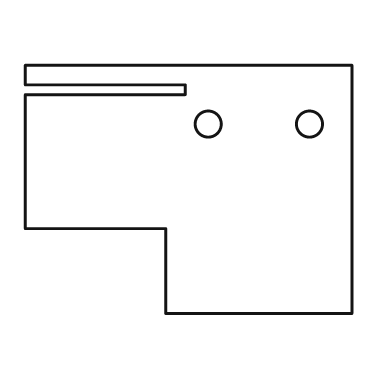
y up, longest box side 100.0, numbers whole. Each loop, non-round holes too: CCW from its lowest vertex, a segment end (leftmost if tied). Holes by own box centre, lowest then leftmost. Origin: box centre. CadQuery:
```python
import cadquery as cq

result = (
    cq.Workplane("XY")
    .moveTo(-7.0, -38.0)
    .lineTo(50.0, -38.0)
    .lineTo(50.0, 38.0)
    .lineTo(-50.0, 38.0)
    .lineTo(-50.0, 32.0)
    .lineTo(-1.0, 32.0)
    .lineTo(-1.0, 29.0)
    .lineTo(-50.0, 29.0)
    .lineTo(-50.0, -12.0)
    .lineTo(-7.0, -12.0)
    .close()
    .moveTo(6.0, 20.0)
    .circle(4.0)
    .moveTo(37.0, 20.0)
    .circle(4.0)
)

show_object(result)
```